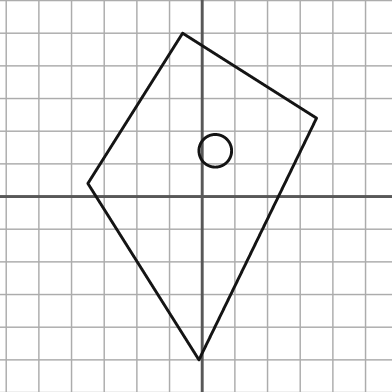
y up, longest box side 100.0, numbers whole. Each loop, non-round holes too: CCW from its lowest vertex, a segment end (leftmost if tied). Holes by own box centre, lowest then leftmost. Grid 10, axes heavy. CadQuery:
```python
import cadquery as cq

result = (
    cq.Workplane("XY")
    .moveTo(-1.0, -50.0)
    .lineTo(35.0, 24.0)
    .lineTo(-6.0, 50.0)
    .lineTo(-35.0, 4.0)
    .close()
    .moveTo(4.0, 14.0)
    .circle(5.0)
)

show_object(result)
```